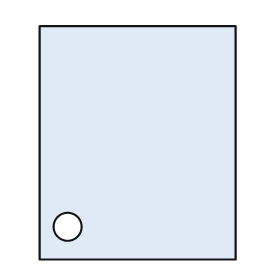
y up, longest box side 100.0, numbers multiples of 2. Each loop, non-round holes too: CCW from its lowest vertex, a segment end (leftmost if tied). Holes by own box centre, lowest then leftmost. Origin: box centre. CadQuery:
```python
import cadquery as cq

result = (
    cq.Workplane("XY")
    .moveTo(-42.0, -50.0)
    .lineTo(42.0, -50.0)
    .lineTo(42.0, 50.0)
    .lineTo(-42.0, 50.0)
    .close()
    .moveTo(-30.0, -36.0)
    .circle(6.0)
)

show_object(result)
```